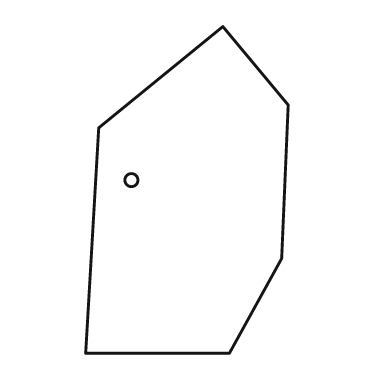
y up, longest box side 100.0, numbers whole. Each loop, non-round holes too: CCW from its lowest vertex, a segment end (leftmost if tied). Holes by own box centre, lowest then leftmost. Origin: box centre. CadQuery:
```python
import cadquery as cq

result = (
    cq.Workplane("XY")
    .moveTo(-31.0, -50.0)
    .lineTo(13.0, -50.0)
    .lineTo(29.0, -21.0)
    .lineTo(31.0, 26.0)
    .lineTo(11.0, 50.0)
    .lineTo(-27.0, 19.0)
    .close()
    .moveTo(-17.0, 3.0)
    .circle(2.0)
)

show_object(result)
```